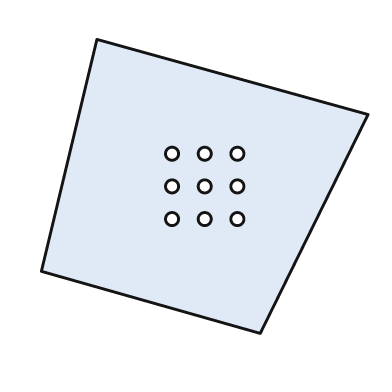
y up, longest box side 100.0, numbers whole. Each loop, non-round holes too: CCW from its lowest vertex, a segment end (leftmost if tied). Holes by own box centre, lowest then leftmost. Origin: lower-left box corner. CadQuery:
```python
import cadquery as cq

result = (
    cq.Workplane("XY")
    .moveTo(67.0, 0.0)
    .lineTo(100.0, 67.0)
    .lineTo(17.0, 90.0)
    .lineTo(0.0, 19.0)
    .close()
    .moveTo(40.0, 35.0)
    .circle(2.0)
    .moveTo(50.0, 35.0)
    .circle(2.0)
    .moveTo(60.0, 35.0)
    .circle(2.0)
    .moveTo(40.0, 45.0)
    .circle(2.0)
    .moveTo(50.0, 45.0)
    .circle(2.0)
    .moveTo(60.0, 45.0)
    .circle(2.0)
    .moveTo(40.0, 55.0)
    .circle(2.0)
    .moveTo(50.0, 55.0)
    .circle(2.0)
    .moveTo(60.0, 55.0)
    .circle(2.0)
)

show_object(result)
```